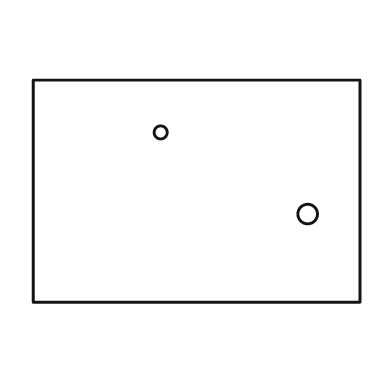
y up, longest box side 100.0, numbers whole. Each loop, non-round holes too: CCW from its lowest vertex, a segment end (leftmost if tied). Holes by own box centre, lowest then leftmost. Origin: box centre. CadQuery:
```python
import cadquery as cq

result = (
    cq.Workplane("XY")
    .moveTo(-50.0, -34.0)
    .lineTo(50.0, -34.0)
    .lineTo(50.0, 34.0)
    .lineTo(-50.0, 34.0)
    .close()
    .moveTo(34.0, -7.0)
    .circle(3.0)
    .moveTo(-11.0, 18.0)
    .circle(2.0)
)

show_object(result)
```